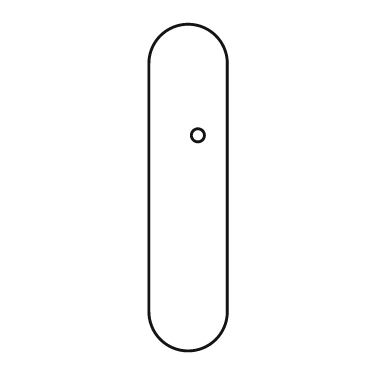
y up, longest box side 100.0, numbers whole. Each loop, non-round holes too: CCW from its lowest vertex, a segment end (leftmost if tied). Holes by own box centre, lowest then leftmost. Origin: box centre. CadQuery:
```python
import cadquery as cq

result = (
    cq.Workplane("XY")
    .moveTo(-12.0, -38.0)
    .threePointArc((0.0, -50.0), (12.0, -38.0))
    .lineTo(12.0, 38.0)
    .threePointArc((0.0, 50.0), (-12.0, 38.0))
    .close()
    .moveTo(3.0, 16.0)
    .circle(2.0)
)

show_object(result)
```